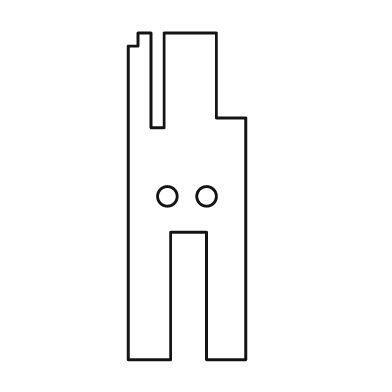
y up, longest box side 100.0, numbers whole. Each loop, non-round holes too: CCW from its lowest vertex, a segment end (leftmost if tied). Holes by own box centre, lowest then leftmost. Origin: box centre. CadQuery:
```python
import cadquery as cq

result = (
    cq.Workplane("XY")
    .moveTo(-18.0, -50.0)
    .lineTo(-5.0, -50.0)
    .lineTo(-5.0, -11.0)
    .lineTo(6.0, -11.0)
    .lineTo(6.0, -50.0)
    .lineTo(18.0, -50.0)
    .lineTo(18.0, 24.0)
    .lineTo(9.0, 24.0)
    .lineTo(9.0, 50.0)
    .lineTo(-7.0, 50.0)
    .lineTo(-7.0, 21.0)
    .lineTo(-11.0, 21.0)
    .lineTo(-11.0, 50.0)
    .lineTo(-15.0, 50.0)
    .lineTo(-15.0, 46.0)
    .lineTo(-18.0, 46.0)
    .close()
    .moveTo(-6.0, 0.0)
    .circle(3.0)
    .moveTo(6.0, 0.0)
    .circle(3.0)
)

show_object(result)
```